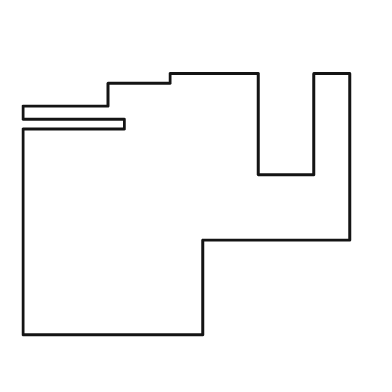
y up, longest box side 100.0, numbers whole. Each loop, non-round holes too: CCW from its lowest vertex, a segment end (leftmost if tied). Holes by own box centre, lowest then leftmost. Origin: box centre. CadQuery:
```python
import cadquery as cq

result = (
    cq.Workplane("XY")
    .moveTo(-50.0, -40.0)
    .lineTo(5.0, -40.0)
    .lineTo(5.0, -11.0)
    .lineTo(50.0, -11.0)
    .lineTo(50.0, 40.0)
    .lineTo(39.0, 40.0)
    .lineTo(39.0, 9.0)
    .lineTo(22.0, 9.0)
    .lineTo(22.0, 40.0)
    .lineTo(-5.0, 40.0)
    .lineTo(-5.0, 37.0)
    .lineTo(-24.0, 37.0)
    .lineTo(-24.0, 30.0)
    .lineTo(-50.0, 30.0)
    .lineTo(-50.0, 26.0)
    .lineTo(-19.0, 26.0)
    .lineTo(-19.0, 23.0)
    .lineTo(-50.0, 23.0)
    .close()
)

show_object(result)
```